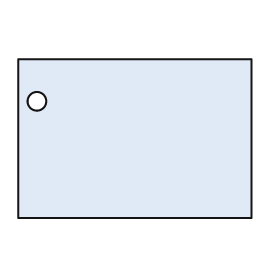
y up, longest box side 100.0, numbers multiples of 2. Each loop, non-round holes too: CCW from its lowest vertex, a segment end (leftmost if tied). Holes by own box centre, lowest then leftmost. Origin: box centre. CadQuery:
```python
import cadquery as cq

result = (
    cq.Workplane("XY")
    .moveTo(-50.0, -34.0)
    .lineTo(50.0, -34.0)
    .lineTo(50.0, 34.0)
    .lineTo(-50.0, 34.0)
    .close()
    .moveTo(-42.0, 16.0)
    .circle(4.0)
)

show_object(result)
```